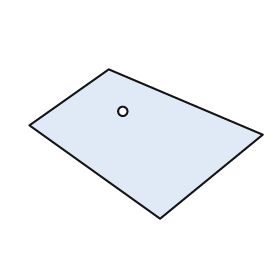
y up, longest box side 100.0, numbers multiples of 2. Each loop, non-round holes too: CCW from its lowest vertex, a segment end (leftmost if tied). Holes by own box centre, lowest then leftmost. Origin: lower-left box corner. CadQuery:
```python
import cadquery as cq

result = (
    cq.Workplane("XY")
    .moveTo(56.0, 0.0)
    .lineTo(100.0, 36.0)
    .lineTo(34.0, 64.0)
    .lineTo(0.0, 40.0)
    .close()
    .moveTo(40.0, 46.0)
    .circle(2.0)
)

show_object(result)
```